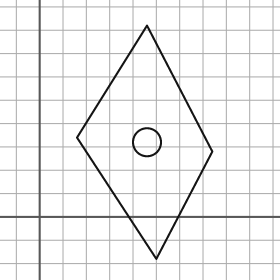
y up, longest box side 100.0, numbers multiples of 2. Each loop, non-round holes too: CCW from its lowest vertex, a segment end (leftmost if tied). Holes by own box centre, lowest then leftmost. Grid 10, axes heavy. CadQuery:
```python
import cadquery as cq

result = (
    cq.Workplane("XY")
    .moveTo(50.0, -18.0)
    .lineTo(74.0, 28.0)
    .lineTo(46.0, 82.0)
    .lineTo(16.0, 34.0)
    .close()
    .moveTo(46.0, 32.0)
    .circle(6.0)
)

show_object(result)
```